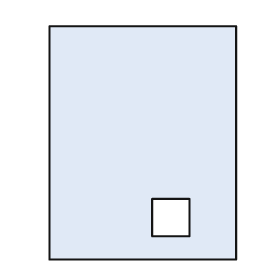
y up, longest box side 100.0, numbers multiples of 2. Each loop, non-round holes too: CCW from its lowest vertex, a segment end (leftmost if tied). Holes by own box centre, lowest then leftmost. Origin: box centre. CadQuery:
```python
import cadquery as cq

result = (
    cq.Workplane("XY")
    .moveTo(-40.0, -50.0)
    .lineTo(40.0, -50.0)
    .lineTo(40.0, 50.0)
    .lineTo(-40.0, 50.0)
    .close()
    .moveTo(4.0, -40.0)
    .lineTo(20.0, -40.0)
    .lineTo(20.0, -24.0)
    .lineTo(4.0, -24.0)
    .close()
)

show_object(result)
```